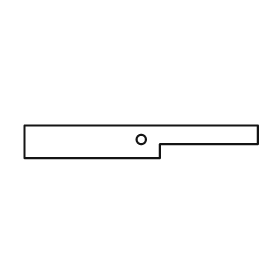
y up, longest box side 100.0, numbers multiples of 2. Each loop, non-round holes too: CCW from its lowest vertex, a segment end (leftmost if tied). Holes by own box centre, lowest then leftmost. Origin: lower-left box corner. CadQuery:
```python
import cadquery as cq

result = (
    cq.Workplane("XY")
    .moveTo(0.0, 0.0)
    .lineTo(58.0, 0.0)
    .lineTo(58.0, 6.0)
    .lineTo(100.0, 6.0)
    .lineTo(100.0, 14.0)
    .lineTo(0.0, 14.0)
    .close()
    .moveTo(50.0, 8.0)
    .circle(2.0)
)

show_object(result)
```